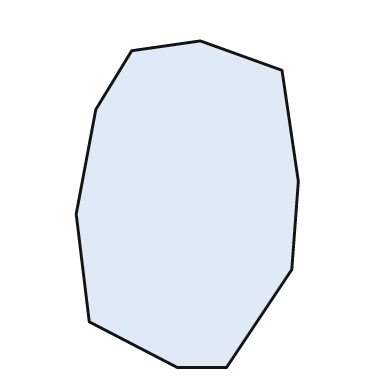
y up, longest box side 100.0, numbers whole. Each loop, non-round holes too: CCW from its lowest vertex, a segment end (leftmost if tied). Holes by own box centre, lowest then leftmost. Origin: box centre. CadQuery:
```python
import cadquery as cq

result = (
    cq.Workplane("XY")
    .moveTo(-3.0, -50.0)
    .lineTo(12.0, -50.0)
    .lineTo(32.0, -20.0)
    .lineTo(34.0, 7.0)
    .lineTo(29.0, 41.0)
    .lineTo(4.0, 50.0)
    .lineTo(-17.0, 47.0)
    .lineTo(-28.0, 29.0)
    .lineTo(-34.0, -3.0)
    .lineTo(-30.0, -36.0)
    .close()
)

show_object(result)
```